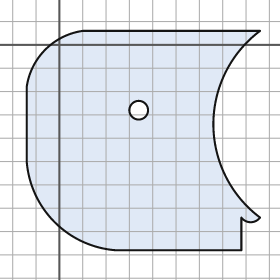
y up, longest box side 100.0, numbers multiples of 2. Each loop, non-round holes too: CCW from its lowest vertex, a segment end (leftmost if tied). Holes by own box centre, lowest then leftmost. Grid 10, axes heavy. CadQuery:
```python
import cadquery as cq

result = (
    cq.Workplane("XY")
    .moveTo(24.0, -88.0)
    .lineTo(78.0, -88.0)
    .lineTo(78.0, -74.0)
    .threePointArc((82.0, -76.0), (86.0, -74.0))
    .threePointArc((66.0, -34.0), (86.0, 6.0))
    .lineTo(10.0, 6.0)
    .threePointArc((-6.0, -2.0), (-14.0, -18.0))
    .lineTo(-14.0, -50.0)
    .threePointArc((-2.0, -76.0), (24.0, -88.0))
    .close()
    .moveTo(34.0, -28.0)
    .circle(4.0)
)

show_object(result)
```